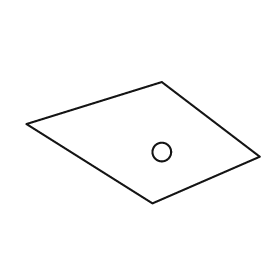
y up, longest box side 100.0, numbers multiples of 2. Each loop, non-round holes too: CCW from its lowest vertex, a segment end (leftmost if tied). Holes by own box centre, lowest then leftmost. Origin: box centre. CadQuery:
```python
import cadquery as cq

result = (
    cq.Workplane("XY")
    .moveTo(4.0, -26.0)
    .lineTo(50.0, -6.0)
    .lineTo(8.0, 26.0)
    .lineTo(-50.0, 8.0)
    .close()
    .moveTo(8.0, -4.0)
    .circle(4.0)
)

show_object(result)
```